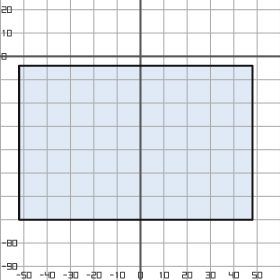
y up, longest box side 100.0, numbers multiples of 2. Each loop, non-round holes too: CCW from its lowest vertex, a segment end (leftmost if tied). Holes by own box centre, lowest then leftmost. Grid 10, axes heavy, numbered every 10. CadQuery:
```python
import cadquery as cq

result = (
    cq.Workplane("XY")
    .moveTo(-52.0, -70.0)
    .lineTo(48.0, -70.0)
    .lineTo(48.0, -4.0)
    .lineTo(-52.0, -4.0)
    .close()
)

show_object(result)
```